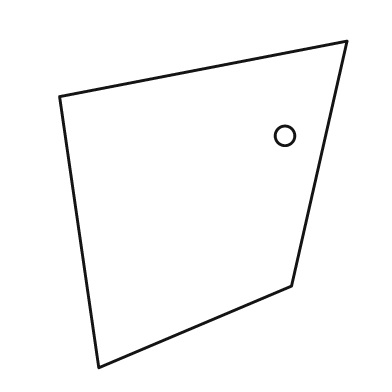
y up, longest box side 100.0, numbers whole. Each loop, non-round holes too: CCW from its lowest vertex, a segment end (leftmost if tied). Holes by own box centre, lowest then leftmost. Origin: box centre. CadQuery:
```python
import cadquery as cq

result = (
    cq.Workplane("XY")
    .moveTo(-32.0, -50.0)
    .lineTo(27.0, -25.0)
    .lineTo(44.0, 50.0)
    .lineTo(-44.0, 33.0)
    .close()
    .moveTo(25.0, 21.0)
    .circle(3.0)
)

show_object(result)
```